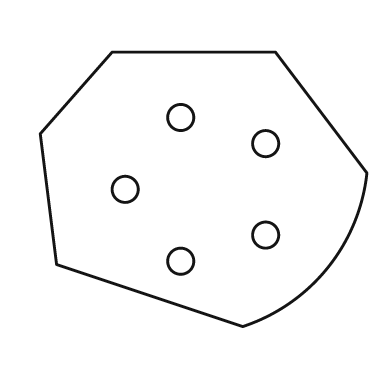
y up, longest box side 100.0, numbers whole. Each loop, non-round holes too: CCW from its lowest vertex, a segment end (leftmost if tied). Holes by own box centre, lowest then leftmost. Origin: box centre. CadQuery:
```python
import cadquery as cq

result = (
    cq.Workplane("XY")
    .moveTo(12.0, -42.0)
    .threePointArc((38.0, -24.0), (50.0, 5.0))
    .lineTo(22.0, 42.0)
    .lineTo(-28.0, 42.0)
    .lineTo(-50.0, 17.0)
    .lineTo(-45.0, -23.0)
    .close()
    .moveTo(-7.0, -22.0)
    .circle(4.0)
    .moveTo(19.0, -14.0)
    .circle(4.0)
    .moveTo(-24.0, 0.0)
    .circle(4.0)
    .moveTo(19.0, 14.0)
    .circle(4.0)
    .moveTo(-7.0, 22.0)
    .circle(4.0)
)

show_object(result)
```